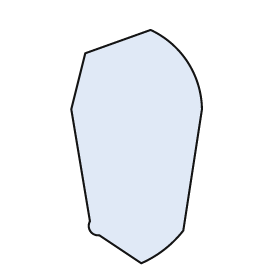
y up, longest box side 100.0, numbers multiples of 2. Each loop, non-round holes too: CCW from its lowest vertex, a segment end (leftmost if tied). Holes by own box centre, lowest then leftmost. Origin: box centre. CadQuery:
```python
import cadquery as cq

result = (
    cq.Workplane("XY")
    .moveTo(2.0, -50.0)
    .threePointArc((12.0, -44.0), (20.0, -36.0))
    .lineTo(28.0, 16.0)
    .threePointArc((22.0, 36.0), (6.0, 50.0))
    .lineTo(-22.0, 40.0)
    .lineTo(-28.0, 16.0)
    .lineTo(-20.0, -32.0)
    .threePointArc((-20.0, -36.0), (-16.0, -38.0))
    .close()
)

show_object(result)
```